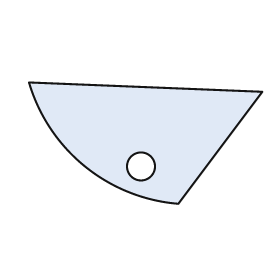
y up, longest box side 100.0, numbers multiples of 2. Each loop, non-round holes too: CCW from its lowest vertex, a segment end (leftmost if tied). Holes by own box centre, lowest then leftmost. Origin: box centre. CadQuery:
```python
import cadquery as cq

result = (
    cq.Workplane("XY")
    .moveTo(14.0, -26.0)
    .lineTo(50.0, 22.0)
    .lineTo(-50.0, 26.0)
    .threePointArc((-26.0, -10.0), (14.0, -26.0))
    .close()
    .moveTo(-2.0, -10.0)
    .circle(6.0)
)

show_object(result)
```